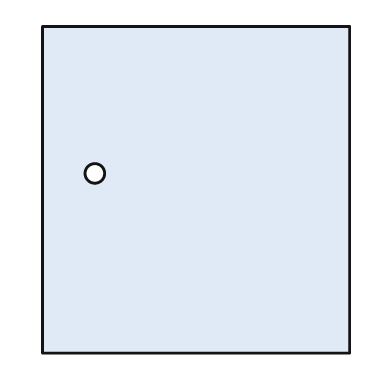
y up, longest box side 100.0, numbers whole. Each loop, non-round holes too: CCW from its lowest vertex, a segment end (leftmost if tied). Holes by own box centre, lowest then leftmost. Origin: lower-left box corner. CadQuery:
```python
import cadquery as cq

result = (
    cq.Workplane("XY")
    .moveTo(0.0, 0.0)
    .lineTo(94.0, 0.0)
    .lineTo(94.0, 100.0)
    .lineTo(0.0, 100.0)
    .close()
    .moveTo(16.0, 55.0)
    .circle(3.0)
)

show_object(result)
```